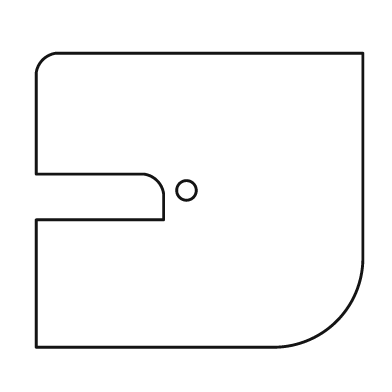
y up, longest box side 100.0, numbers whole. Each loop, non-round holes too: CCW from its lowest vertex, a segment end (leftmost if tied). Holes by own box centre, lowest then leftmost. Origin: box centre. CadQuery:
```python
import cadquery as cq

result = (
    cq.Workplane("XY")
    .moveTo(-50.0, -45.0)
    .lineTo(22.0, -45.0)
    .threePointArc((42.0, -37.0), (50.0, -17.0))
    .lineTo(50.0, 45.0)
    .lineTo(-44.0, 45.0)
    .threePointArc((-48.0, 43.0), (-50.0, 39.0))
    .lineTo(-50.0, 8.0)
    .lineTo(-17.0, 8.0)
    .threePointArc((-13.0, 6.0), (-11.0, 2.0))
    .lineTo(-11.0, -6.0)
    .lineTo(-50.0, -6.0)
    .close()
    .moveTo(-4.0, 3.0)
    .circle(3.0)
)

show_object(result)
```